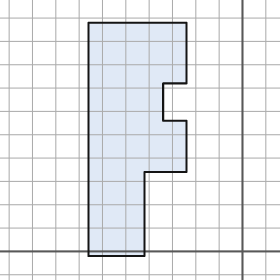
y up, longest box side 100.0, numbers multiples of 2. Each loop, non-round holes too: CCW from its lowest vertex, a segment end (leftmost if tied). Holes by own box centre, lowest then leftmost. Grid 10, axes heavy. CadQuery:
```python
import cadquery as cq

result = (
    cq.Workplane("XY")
    .moveTo(-66.0, -2.0)
    .lineTo(-42.0, -2.0)
    .lineTo(-42.0, 34.0)
    .lineTo(-24.0, 34.0)
    .lineTo(-24.0, 56.0)
    .lineTo(-34.0, 56.0)
    .lineTo(-34.0, 72.0)
    .lineTo(-24.0, 72.0)
    .lineTo(-24.0, 98.0)
    .lineTo(-66.0, 98.0)
    .close()
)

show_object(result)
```